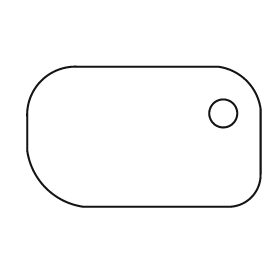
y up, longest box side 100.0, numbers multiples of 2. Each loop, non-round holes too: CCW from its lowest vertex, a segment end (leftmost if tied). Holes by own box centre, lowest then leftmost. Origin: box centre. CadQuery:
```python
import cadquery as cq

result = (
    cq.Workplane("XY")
    .moveTo(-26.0, -30.0)
    .lineTo(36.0, -30.0)
    .threePointArc((46.0, -26.0), (50.0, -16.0))
    .lineTo(50.0, 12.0)
    .threePointArc((44.0, 24.0), (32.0, 30.0))
    .lineTo(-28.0, 30.0)
    .threePointArc((-44.0, 24.0), (-50.0, 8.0))
    .lineTo(-50.0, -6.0)
    .threePointArc((-42.0, -22.0), (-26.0, -30.0))
    .close()
    .moveTo(34.0, 10.0)
    .circle(6.0)
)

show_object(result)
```